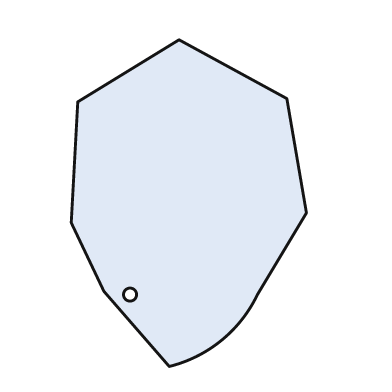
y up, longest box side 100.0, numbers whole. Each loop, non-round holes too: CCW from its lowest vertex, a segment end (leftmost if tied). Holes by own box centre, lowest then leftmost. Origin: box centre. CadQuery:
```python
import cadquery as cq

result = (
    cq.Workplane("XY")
    .moveTo(-6.0, -50.0)
    .threePointArc((10.0, -42.0), (21.0, -28.0))
    .lineTo(36.0, -3.0)
    .lineTo(30.0, 32.0)
    .lineTo(-3.0, 50.0)
    .lineTo(-34.0, 31.0)
    .lineTo(-36.0, -6.0)
    .lineTo(-26.0, -27.0)
    .close()
    .moveTo(-18.0, -28.0)
    .circle(2.0)
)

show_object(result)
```